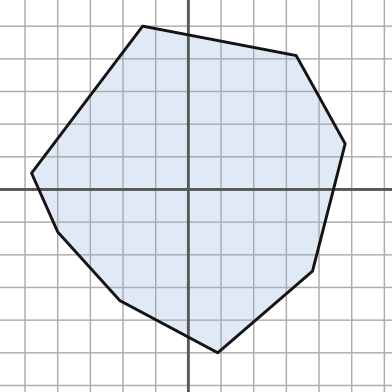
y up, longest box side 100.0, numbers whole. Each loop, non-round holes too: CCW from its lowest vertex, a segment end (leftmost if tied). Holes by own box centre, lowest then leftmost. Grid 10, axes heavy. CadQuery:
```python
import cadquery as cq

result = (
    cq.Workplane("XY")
    .moveTo(9.0, -50.0)
    .lineTo(38.0, -25.0)
    .lineTo(48.0, 14.0)
    .lineTo(33.0, 41.0)
    .lineTo(-14.0, 50.0)
    .lineTo(-48.0, 5.0)
    .lineTo(-40.0, -13.0)
    .lineTo(-21.0, -34.0)
    .close()
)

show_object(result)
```